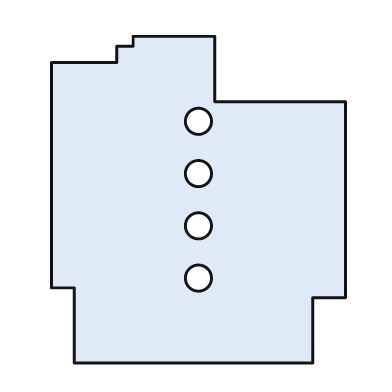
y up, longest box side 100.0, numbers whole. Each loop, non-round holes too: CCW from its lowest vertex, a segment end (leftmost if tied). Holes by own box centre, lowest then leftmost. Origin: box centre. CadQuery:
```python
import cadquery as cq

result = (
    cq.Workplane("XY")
    .moveTo(-38.0, -50.0)
    .lineTo(35.0, -50.0)
    .lineTo(35.0, -30.0)
    .lineTo(45.0, -30.0)
    .lineTo(45.0, 30.0)
    .lineTo(5.0, 30.0)
    .lineTo(5.0, 50.0)
    .lineTo(-20.0, 50.0)
    .lineTo(-20.0, 47.0)
    .lineTo(-25.0, 47.0)
    .lineTo(-25.0, 42.0)
    .lineTo(-45.0, 42.0)
    .lineTo(-45.0, -27.0)
    .lineTo(-38.0, -27.0)
    .close()
    .moveTo(0.0, -24.0)
    .circle(4.0)
    .moveTo(0.0, -8.0)
    .circle(4.0)
    .moveTo(0.0, 8.0)
    .circle(4.0)
    .moveTo(0.0, 24.0)
    .circle(4.0)
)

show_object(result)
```